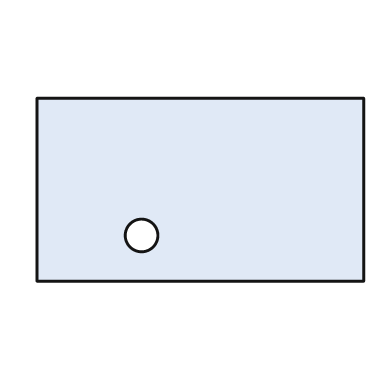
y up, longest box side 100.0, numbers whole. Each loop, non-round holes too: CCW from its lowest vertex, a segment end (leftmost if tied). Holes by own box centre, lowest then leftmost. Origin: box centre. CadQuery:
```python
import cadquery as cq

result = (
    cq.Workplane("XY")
    .moveTo(-50.0, -28.0)
    .lineTo(50.0, -28.0)
    .lineTo(50.0, 28.0)
    .lineTo(-50.0, 28.0)
    .close()
    .moveTo(-18.0, -14.0)
    .circle(5.0)
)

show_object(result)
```